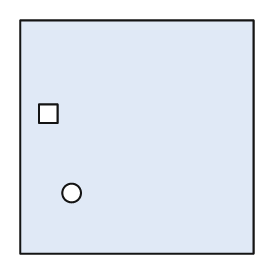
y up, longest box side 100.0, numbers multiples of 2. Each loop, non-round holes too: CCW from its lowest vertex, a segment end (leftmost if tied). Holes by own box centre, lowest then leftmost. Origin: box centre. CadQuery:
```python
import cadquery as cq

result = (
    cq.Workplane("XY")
    .moveTo(-50.0, -50.0)
    .lineTo(50.0, -50.0)
    .lineTo(50.0, 50.0)
    .lineTo(-50.0, 50.0)
    .close()
    .moveTo(-28.0, -24.0)
    .circle(4.0)
    .moveTo(-42.0, 6.0)
    .lineTo(-34.0, 6.0)
    .lineTo(-34.0, 14.0)
    .lineTo(-42.0, 14.0)
    .close()
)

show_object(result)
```